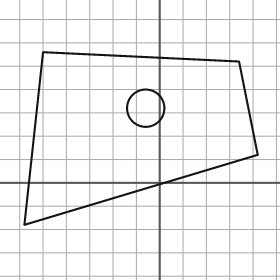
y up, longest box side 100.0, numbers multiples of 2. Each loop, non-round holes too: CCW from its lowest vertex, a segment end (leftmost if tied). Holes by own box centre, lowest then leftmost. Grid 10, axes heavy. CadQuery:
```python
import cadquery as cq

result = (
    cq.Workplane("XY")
    .moveTo(-58.0, -18.0)
    .lineTo(42.0, 12.0)
    .lineTo(34.0, 52.0)
    .lineTo(-50.0, 56.0)
    .close()
    .moveTo(-6.0, 32.0)
    .circle(8.0)
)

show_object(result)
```